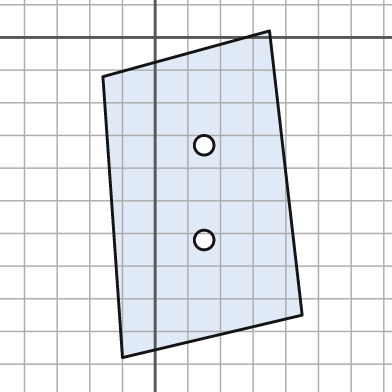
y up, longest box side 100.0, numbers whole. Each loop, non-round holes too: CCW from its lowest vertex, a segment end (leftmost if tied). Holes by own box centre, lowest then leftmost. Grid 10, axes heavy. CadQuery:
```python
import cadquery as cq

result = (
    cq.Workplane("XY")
    .moveTo(-10.0, -98.0)
    .lineTo(45.0, -85.0)
    .lineTo(35.0, 2.0)
    .lineTo(-16.0, -12.0)
    .close()
    .moveTo(15.0, -62.0)
    .circle(3.0)
    .moveTo(15.0, -33.0)
    .circle(3.0)
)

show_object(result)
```